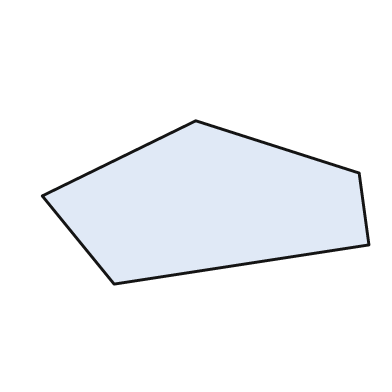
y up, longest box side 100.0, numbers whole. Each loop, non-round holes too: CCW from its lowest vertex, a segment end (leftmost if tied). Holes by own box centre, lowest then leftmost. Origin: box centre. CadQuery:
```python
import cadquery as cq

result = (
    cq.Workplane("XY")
    .moveTo(-28.0, -25.0)
    .lineTo(50.0, -13.0)
    .lineTo(47.0, 9.0)
    .lineTo(-3.0, 25.0)
    .lineTo(-50.0, 2.0)
    .close()
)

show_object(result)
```